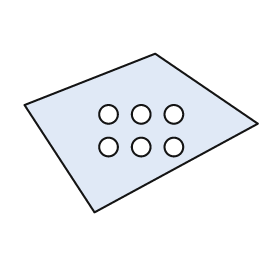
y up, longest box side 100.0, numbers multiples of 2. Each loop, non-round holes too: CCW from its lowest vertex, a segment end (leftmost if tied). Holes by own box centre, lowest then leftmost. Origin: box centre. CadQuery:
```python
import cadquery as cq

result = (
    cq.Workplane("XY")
    .moveTo(-20.0, -34.0)
    .lineTo(50.0, 4.0)
    .lineTo(6.0, 34.0)
    .lineTo(-50.0, 12.0)
    .close()
    .moveTo(-14.0, -6.0)
    .circle(4.0)
    .moveTo(0.0, -6.0)
    .circle(4.0)
    .moveTo(14.0, -6.0)
    .circle(4.0)
    .moveTo(-14.0, 8.0)
    .circle(4.0)
    .moveTo(0.0, 8.0)
    .circle(4.0)
    .moveTo(14.0, 8.0)
    .circle(4.0)
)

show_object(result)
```